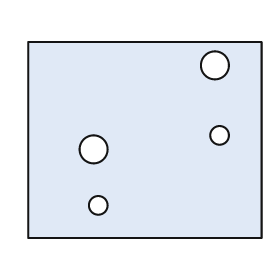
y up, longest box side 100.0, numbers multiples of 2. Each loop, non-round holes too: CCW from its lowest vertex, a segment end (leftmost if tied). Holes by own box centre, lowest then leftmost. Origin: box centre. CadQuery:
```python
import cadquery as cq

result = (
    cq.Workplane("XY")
    .moveTo(-50.0, -42.0)
    .lineTo(50.0, -42.0)
    .lineTo(50.0, 42.0)
    .lineTo(-50.0, 42.0)
    .close()
    .moveTo(-20.0, -28.0)
    .circle(4.0)
    .moveTo(-22.0, -4.0)
    .circle(6.0)
    .moveTo(32.0, 2.0)
    .circle(4.0)
    .moveTo(30.0, 32.0)
    .circle(6.0)
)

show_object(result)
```